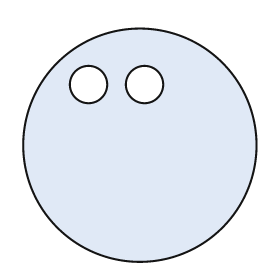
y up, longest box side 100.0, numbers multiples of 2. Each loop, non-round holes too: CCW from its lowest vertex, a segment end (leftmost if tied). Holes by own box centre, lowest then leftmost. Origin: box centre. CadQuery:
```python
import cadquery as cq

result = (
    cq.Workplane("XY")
    .moveTo(0.0, 0.0)
    .circle(50.0)
    .moveTo(-22.0, 26.0)
    .circle(8.0)
    .moveTo(2.0, 26.0)
    .circle(8.0)
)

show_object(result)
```